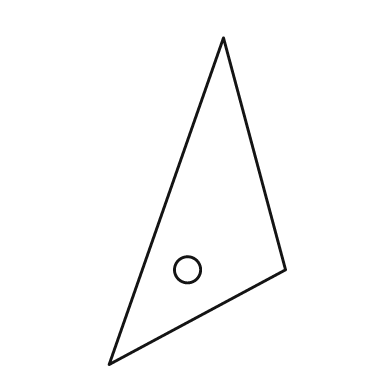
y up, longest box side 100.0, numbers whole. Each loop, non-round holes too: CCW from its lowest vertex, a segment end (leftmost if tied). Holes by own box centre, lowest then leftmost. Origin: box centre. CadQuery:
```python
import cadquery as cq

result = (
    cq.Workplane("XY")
    .moveTo(-27.0, -50.0)
    .lineTo(27.0, -21.0)
    .lineTo(8.0, 50.0)
    .close()
    .moveTo(-3.0, -21.0)
    .circle(4.0)
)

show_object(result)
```